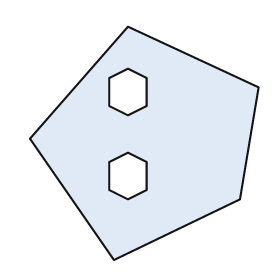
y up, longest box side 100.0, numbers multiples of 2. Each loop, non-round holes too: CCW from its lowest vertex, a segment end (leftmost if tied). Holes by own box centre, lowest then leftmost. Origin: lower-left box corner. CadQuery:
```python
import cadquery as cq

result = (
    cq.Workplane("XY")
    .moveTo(36.0, 0.0)
    .lineTo(90.0, 26.0)
    .lineTo(98.0, 74.0)
    .lineTo(42.0, 100.0)
    .lineTo(0.0, 52.0)
    .close()
    .moveTo(42.0, 26.0)
    .lineTo(50.0, 30.0)
    .lineTo(50.0, 42.0)
    .lineTo(42.0, 46.0)
    .lineTo(34.0, 42.0)
    .lineTo(34.0, 30.0)
    .close()
    .moveTo(42.0, 62.0)
    .lineTo(50.0, 66.0)
    .lineTo(50.0, 78.0)
    .lineTo(42.0, 82.0)
    .lineTo(34.0, 78.0)
    .lineTo(34.0, 66.0)
    .close()
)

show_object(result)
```